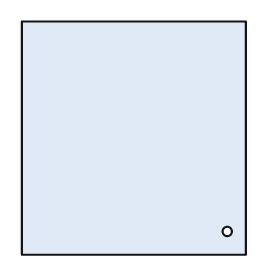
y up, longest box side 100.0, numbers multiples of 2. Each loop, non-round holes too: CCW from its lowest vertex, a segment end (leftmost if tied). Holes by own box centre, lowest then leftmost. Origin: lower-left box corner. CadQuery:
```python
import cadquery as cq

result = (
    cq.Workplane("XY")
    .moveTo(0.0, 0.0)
    .lineTo(96.0, 0.0)
    .lineTo(96.0, 100.0)
    .lineTo(0.0, 100.0)
    .close()
    .moveTo(88.0, 10.0)
    .circle(2.0)
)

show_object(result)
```